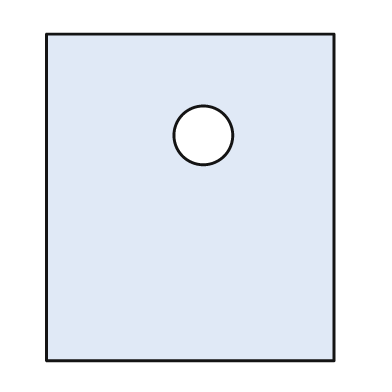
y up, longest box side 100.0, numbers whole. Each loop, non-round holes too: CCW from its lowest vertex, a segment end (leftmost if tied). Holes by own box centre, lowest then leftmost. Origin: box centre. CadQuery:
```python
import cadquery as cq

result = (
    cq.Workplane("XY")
    .moveTo(-44.0, -50.0)
    .lineTo(44.0, -50.0)
    .lineTo(44.0, 50.0)
    .lineTo(-44.0, 50.0)
    .close()
    .moveTo(4.0, 19.0)
    .circle(9.0)
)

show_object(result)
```